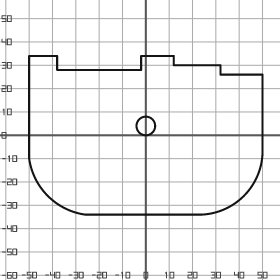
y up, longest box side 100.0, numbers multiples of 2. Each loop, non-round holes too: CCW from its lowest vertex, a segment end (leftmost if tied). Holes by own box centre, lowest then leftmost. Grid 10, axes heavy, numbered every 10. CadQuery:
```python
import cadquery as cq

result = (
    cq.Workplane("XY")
    .moveTo(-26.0, -34.0)
    .lineTo(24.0, -34.0)
    .threePointArc((42.0, -26.0), (50.0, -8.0))
    .lineTo(50.0, 26.0)
    .lineTo(32.0, 26.0)
    .lineTo(32.0, 30.0)
    .lineTo(12.0, 30.0)
    .lineTo(12.0, 34.0)
    .lineTo(-2.0, 34.0)
    .lineTo(-2.0, 28.0)
    .lineTo(-38.0, 28.0)
    .lineTo(-38.0, 34.0)
    .lineTo(-50.0, 34.0)
    .lineTo(-50.0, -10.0)
    .threePointArc((-42.0, -26.0), (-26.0, -34.0))
    .close()
    .moveTo(0.0, 4.0)
    .circle(4.0)
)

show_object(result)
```